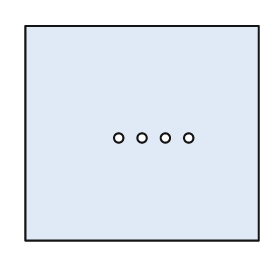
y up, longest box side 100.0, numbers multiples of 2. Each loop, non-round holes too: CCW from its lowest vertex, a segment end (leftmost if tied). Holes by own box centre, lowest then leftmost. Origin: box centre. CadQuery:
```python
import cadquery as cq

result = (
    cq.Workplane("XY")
    .moveTo(-50.0, -46.0)
    .lineTo(50.0, -46.0)
    .lineTo(50.0, 46.0)
    .lineTo(-50.0, 46.0)
    .close()
    .moveTo(-10.0, -2.0)
    .circle(2.0)
    .moveTo(0.0, -2.0)
    .circle(2.0)
    .moveTo(10.0, -2.0)
    .circle(2.0)
    .moveTo(20.0, -2.0)
    .circle(2.0)
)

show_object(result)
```